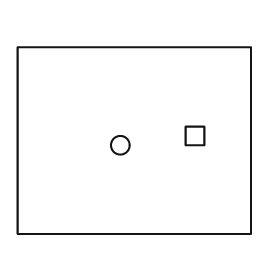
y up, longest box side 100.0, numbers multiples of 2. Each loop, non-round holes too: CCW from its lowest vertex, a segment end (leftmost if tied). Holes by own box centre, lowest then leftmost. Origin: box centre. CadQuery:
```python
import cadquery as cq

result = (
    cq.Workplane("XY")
    .moveTo(-50.0, -40.0)
    .lineTo(50.0, -40.0)
    .lineTo(50.0, 40.0)
    .lineTo(-50.0, 40.0)
    .close()
    .moveTo(-6.0, -2.0)
    .circle(4.0)
    .moveTo(22.0, -2.0)
    .lineTo(30.0, -2.0)
    .lineTo(30.0, 6.0)
    .lineTo(22.0, 6.0)
    .close()
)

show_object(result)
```